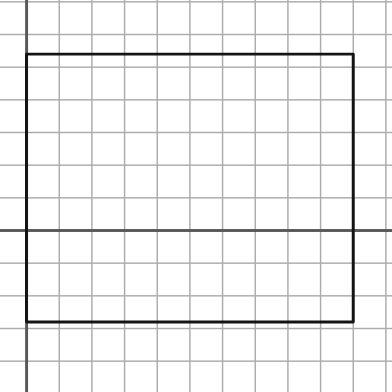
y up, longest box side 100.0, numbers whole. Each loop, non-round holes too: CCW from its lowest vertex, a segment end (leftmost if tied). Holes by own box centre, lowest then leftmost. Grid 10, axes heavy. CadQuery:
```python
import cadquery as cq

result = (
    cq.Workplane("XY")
    .moveTo(0.0, -28.0)
    .lineTo(100.0, -28.0)
    .lineTo(100.0, 54.0)
    .lineTo(0.0, 54.0)
    .close()
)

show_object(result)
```